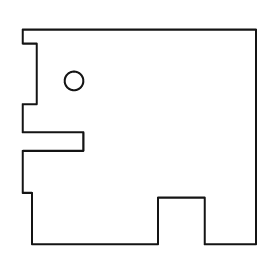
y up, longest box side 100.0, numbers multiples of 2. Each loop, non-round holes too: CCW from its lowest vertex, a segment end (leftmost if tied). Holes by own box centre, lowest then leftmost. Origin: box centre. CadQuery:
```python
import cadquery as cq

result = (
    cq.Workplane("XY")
    .moveTo(-46.0, -46.0)
    .lineTo(8.0, -46.0)
    .lineTo(8.0, -26.0)
    .lineTo(28.0, -26.0)
    .lineTo(28.0, -46.0)
    .lineTo(50.0, -46.0)
    .lineTo(50.0, 46.0)
    .lineTo(-50.0, 46.0)
    .lineTo(-50.0, 40.0)
    .lineTo(-44.0, 40.0)
    .lineTo(-44.0, 14.0)
    .lineTo(-50.0, 14.0)
    .lineTo(-50.0, 2.0)
    .lineTo(-24.0, 2.0)
    .lineTo(-24.0, -6.0)
    .lineTo(-50.0, -6.0)
    .lineTo(-50.0, -24.0)
    .lineTo(-46.0, -24.0)
    .close()
    .moveTo(-28.0, 24.0)
    .circle(4.0)
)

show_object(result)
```